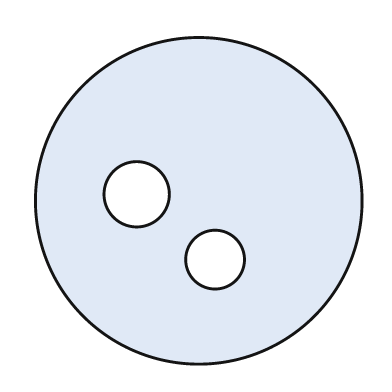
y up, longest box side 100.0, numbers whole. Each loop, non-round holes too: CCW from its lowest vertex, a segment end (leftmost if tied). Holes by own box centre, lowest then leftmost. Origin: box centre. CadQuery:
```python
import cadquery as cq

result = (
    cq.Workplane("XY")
    .moveTo(0.0, 0.0)
    .circle(50.0)
    .moveTo(5.0, -18.0)
    .circle(9.0)
    .moveTo(-19.0, 2.0)
    .circle(10.0)
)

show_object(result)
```